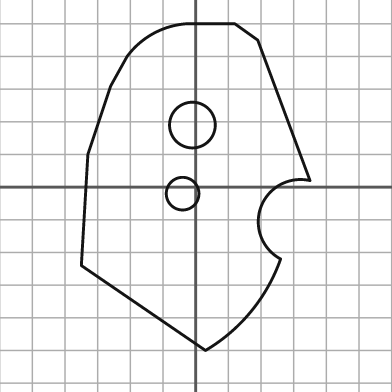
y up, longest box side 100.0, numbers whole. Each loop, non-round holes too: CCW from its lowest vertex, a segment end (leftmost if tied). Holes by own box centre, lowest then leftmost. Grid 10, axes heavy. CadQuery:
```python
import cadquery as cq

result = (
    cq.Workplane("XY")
    .moveTo(3.0, -50.0)
    .threePointArc((17.0, -38.0), (26.0, -22.0))
    .threePointArc((20.0, -6.0), (35.0, 2.0))
    .lineTo(19.0, 45.0)
    .lineTo(12.0, 50.0)
    .lineTo(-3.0, 50.0)
    .threePointArc((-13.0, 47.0), (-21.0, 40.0))
    .lineTo(-26.0, 31.0)
    .lineTo(-33.0, 10.0)
    .lineTo(-35.0, -24.0)
    .close()
    .moveTo(-4.0, -2.0)
    .circle(5.0)
    .moveTo(-1.0, 19.0)
    .circle(7.0)
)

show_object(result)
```